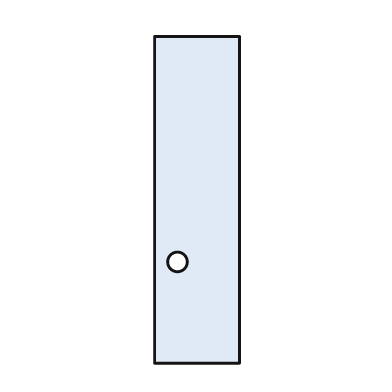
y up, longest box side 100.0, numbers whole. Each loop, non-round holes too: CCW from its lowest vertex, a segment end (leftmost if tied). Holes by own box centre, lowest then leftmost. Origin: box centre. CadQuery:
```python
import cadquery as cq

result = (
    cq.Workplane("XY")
    .moveTo(-13.0, -50.0)
    .lineTo(13.0, -50.0)
    .lineTo(13.0, 50.0)
    .lineTo(-13.0, 50.0)
    .close()
    .moveTo(-6.0, -19.0)
    .circle(3.0)
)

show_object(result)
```